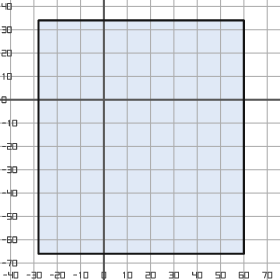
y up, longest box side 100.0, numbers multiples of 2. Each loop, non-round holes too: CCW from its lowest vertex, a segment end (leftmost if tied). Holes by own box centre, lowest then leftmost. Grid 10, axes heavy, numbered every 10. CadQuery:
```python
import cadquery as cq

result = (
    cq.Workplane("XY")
    .moveTo(-28.0, -66.0)
    .lineTo(60.0, -66.0)
    .lineTo(60.0, 34.0)
    .lineTo(-28.0, 34.0)
    .close()
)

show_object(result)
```